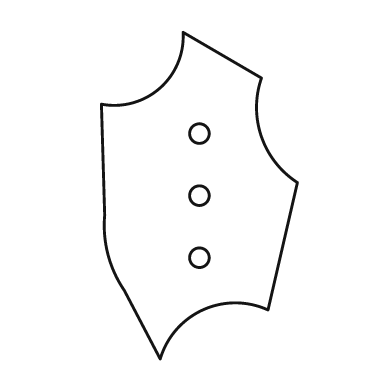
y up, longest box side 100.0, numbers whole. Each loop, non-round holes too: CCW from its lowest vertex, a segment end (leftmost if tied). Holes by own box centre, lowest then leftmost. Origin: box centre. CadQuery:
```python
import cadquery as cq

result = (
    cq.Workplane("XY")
    .moveTo(-12.0, -50.0)
    .threePointArc((1.0, -35.0), (21.0, -35.0))
    .lineTo(30.0, 4.0)
    .threePointArc((19.0, 18.0), (19.0, 36.0))
    .lineTo(-5.0, 50.0)
    .threePointArc((-12.0, 33.0), (-30.0, 28.0))
    .lineTo(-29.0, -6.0)
    .threePointArc((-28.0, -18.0), (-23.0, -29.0))
    .close()
    .moveTo(0.0, -19.0)
    .circle(3.0)
    .moveTo(0.0, 0.0)
    .circle(3.0)
    .moveTo(0.0, 19.0)
    .circle(3.0)
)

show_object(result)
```